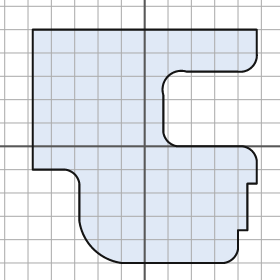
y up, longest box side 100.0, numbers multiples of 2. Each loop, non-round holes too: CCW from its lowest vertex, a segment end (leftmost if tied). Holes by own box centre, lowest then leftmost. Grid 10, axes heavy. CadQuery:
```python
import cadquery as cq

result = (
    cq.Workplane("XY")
    .moveTo(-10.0, -50.0)
    .lineTo(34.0, -50.0)
    .threePointArc((38.0, -48.0), (40.0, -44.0))
    .lineTo(40.0, -36.0)
    .lineTo(44.0, -36.0)
    .lineTo(44.0, -16.0)
    .lineTo(48.0, -16.0)
    .lineTo(48.0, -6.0)
    .threePointArc((46.0, -2.0), (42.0, 0.0))
    .lineTo(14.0, 0.0)
    .threePointArc((10.0, 2.0), (8.0, 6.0))
    .lineTo(8.0, 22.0)
    .threePointArc((10.0, 30.0), (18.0, 32.0))
    .lineTo(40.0, 32.0)
    .threePointArc((46.0, 34.0), (48.0, 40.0))
    .lineTo(48.0, 50.0)
    .lineTo(-48.0, 50.0)
    .lineTo(-48.0, -10.0)
    .lineTo(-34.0, -10.0)
    .threePointArc((-30.0, -12.0), (-28.0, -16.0))
    .lineTo(-28.0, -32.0)
    .threePointArc((-22.0, -44.0), (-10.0, -50.0))
    .close()
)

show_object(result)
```